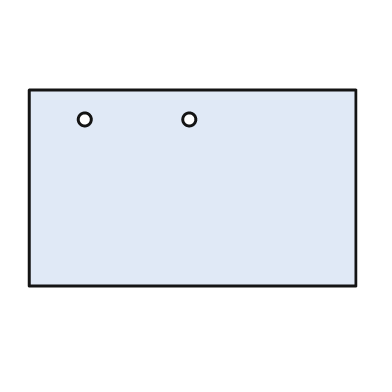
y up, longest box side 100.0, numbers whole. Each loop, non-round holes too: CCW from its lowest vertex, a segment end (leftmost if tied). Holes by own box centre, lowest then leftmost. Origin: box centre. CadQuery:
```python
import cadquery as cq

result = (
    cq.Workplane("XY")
    .moveTo(-50.0, -30.0)
    .lineTo(50.0, -30.0)
    .lineTo(50.0, 30.0)
    .lineTo(-50.0, 30.0)
    .close()
    .moveTo(-33.0, 21.0)
    .circle(2.0)
    .moveTo(-1.0, 21.0)
    .circle(2.0)
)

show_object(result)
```